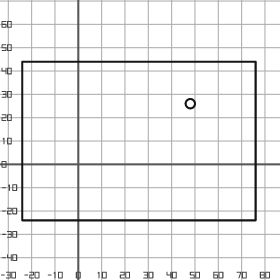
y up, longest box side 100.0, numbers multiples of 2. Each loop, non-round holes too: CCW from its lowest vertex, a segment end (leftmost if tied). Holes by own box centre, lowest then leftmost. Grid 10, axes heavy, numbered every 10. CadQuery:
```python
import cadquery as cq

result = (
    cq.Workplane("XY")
    .moveTo(-24.0, -24.0)
    .lineTo(76.0, -24.0)
    .lineTo(76.0, 44.0)
    .lineTo(-24.0, 44.0)
    .close()
    .moveTo(48.0, 26.0)
    .circle(2.0)
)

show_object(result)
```